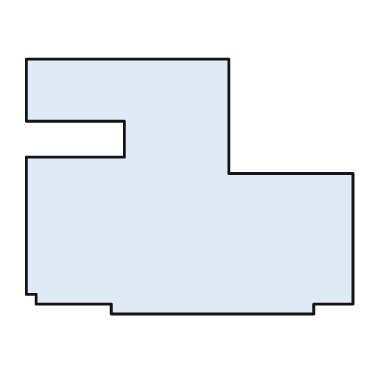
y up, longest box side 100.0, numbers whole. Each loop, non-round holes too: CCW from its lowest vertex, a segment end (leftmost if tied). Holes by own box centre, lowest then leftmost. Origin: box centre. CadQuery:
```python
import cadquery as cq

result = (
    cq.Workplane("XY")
    .moveTo(-24.0, -39.0)
    .lineTo(38.0, -39.0)
    .lineTo(38.0, -36.0)
    .lineTo(50.0, -36.0)
    .lineTo(50.0, 4.0)
    .lineTo(12.0, 4.0)
    .lineTo(12.0, 39.0)
    .lineTo(-50.0, 39.0)
    .lineTo(-50.0, 20.0)
    .lineTo(-20.0, 20.0)
    .lineTo(-20.0, 9.0)
    .lineTo(-50.0, 9.0)
    .lineTo(-50.0, -33.0)
    .lineTo(-47.0, -33.0)
    .lineTo(-47.0, -36.0)
    .lineTo(-24.0, -36.0)
    .close()
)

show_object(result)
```